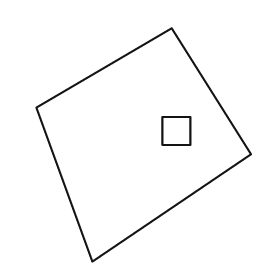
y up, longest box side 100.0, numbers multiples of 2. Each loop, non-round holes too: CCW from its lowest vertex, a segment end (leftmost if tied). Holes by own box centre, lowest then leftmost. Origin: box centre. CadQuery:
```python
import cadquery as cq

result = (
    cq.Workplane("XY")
    .moveTo(-22.0, -50.0)
    .lineTo(46.0, -4.0)
    .lineTo(12.0, 50.0)
    .lineTo(-46.0, 16.0)
    .close()
    .moveTo(8.0, 0.0)
    .lineTo(20.0, 0.0)
    .lineTo(20.0, 12.0)
    .lineTo(8.0, 12.0)
    .close()
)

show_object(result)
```